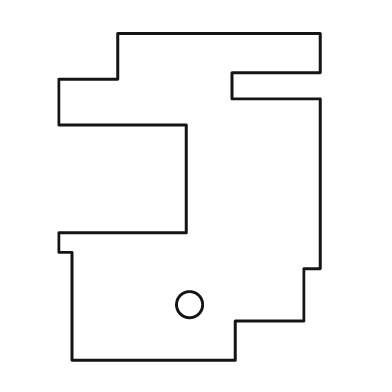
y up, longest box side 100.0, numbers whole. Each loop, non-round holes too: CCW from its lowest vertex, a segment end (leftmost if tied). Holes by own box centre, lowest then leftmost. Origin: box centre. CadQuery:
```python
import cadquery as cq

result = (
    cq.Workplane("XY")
    .moveTo(-36.0, -50.0)
    .lineTo(14.0, -50.0)
    .lineTo(14.0, -38.0)
    .lineTo(35.0, -38.0)
    .lineTo(35.0, -22.0)
    .lineTo(40.0, -22.0)
    .lineTo(40.0, 30.0)
    .lineTo(13.0, 30.0)
    .lineTo(13.0, 38.0)
    .lineTo(40.0, 38.0)
    .lineTo(40.0, 50.0)
    .lineTo(-22.0, 50.0)
    .lineTo(-22.0, 36.0)
    .lineTo(-40.0, 36.0)
    .lineTo(-40.0, 22.0)
    .lineTo(-1.0, 22.0)
    .lineTo(-1.0, -11.0)
    .lineTo(-40.0, -11.0)
    .lineTo(-40.0, -17.0)
    .lineTo(-36.0, -17.0)
    .close()
    .moveTo(0.0, -33.0)
    .circle(4.0)
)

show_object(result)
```